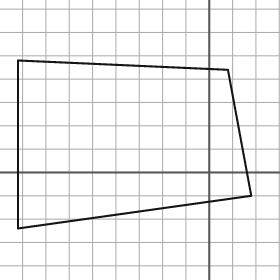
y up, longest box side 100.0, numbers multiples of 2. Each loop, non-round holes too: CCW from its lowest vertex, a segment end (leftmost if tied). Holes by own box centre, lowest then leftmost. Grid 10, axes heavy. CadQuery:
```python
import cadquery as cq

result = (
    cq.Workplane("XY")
    .moveTo(-82.0, -24.0)
    .lineTo(18.0, -10.0)
    .lineTo(8.0, 44.0)
    .lineTo(-82.0, 48.0)
    .close()
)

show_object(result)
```